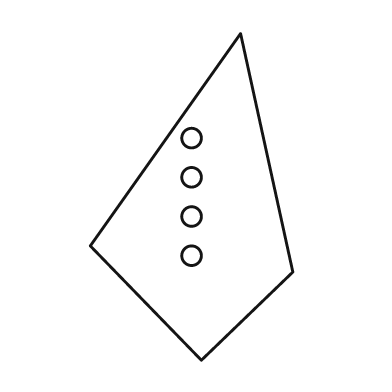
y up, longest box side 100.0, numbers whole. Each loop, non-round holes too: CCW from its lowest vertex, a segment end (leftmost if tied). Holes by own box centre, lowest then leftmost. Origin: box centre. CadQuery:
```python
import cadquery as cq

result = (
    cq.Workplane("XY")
    .moveTo(3.0, -50.0)
    .lineTo(31.0, -23.0)
    .lineTo(15.0, 50.0)
    .lineTo(-31.0, -15.0)
    .close()
    .moveTo(0.0, -18.0)
    .circle(3.0)
    .moveTo(0.0, -6.0)
    .circle(3.0)
    .moveTo(0.0, 6.0)
    .circle(3.0)
    .moveTo(0.0, 18.0)
    .circle(3.0)
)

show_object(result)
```